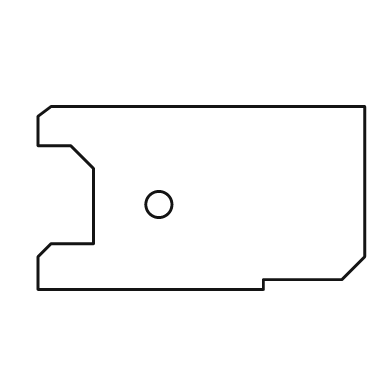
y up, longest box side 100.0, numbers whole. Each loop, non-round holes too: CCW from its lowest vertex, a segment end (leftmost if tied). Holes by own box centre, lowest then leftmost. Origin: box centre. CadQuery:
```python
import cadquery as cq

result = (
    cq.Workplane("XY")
    .moveTo(-50.0, -28.0)
    .lineTo(19.0, -28.0)
    .lineTo(19.0, -25.0)
    .lineTo(43.0, -25.0)
    .lineTo(50.0, -18.0)
    .lineTo(50.0, 28.0)
    .lineTo(-46.0, 28.0)
    .lineTo(-50.0, 25.0)
    .lineTo(-50.0, 16.0)
    .lineTo(-40.0, 16.0)
    .lineTo(-33.0, 9.0)
    .lineTo(-33.0, -14.0)
    .lineTo(-46.0, -14.0)
    .lineTo(-50.0, -18.0)
    .close()
    .moveTo(-13.0, -2.0)
    .circle(4.0)
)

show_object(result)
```